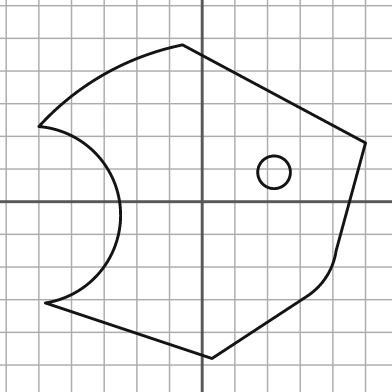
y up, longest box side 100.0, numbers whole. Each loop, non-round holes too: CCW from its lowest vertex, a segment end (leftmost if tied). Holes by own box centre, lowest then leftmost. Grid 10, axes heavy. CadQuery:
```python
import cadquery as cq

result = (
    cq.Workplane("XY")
    .moveTo(3.0, -48.0)
    .lineTo(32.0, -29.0)
    .threePointArc((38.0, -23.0), (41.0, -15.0))
    .lineTo(50.0, 18.0)
    .lineTo(-6.0, 48.0)
    .threePointArc((-30.0, 39.0), (-50.0, 23.0))
    .threePointArc((-25.0, -3.0), (-48.0, -31.0))
    .close()
    .moveTo(22.0, 9.0)
    .circle(5.0)
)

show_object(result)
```